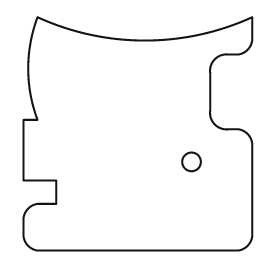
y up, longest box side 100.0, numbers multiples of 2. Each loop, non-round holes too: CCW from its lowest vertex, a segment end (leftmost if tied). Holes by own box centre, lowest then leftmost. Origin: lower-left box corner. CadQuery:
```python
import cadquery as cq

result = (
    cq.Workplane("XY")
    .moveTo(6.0, 0.0)
    .lineTo(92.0, 0.0)
    .threePointArc((96.0, 2.0), (98.0, 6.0))
    .lineTo(98.0, 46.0)
    .threePointArc((96.0, 50.0), (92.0, 52.0))
    .lineTo(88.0, 52.0)
    .threePointArc((82.0, 54.0), (80.0, 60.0))
    .lineTo(80.0, 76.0)
    .threePointArc((82.0, 82.0), (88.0, 84.0))
    .lineTo(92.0, 84.0)
    .threePointArc((96.0, 86.0), (98.0, 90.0))
    .lineTo(98.0, 100.0)
    .threePointArc((52.0, 90.0), (6.0, 100.0))
    .threePointArc((2.0, 78.0), (6.0, 56.0))
    .lineTo(0.0, 56.0)
    .lineTo(0.0, 30.0)
    .lineTo(14.0, 30.0)
    .lineTo(14.0, 20.0)
    .lineTo(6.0, 20.0)
    .threePointArc((2.0, 18.0), (0.0, 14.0))
    .lineTo(0.0, 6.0)
    .threePointArc((2.0, 2.0), (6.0, 0.0))
    .close()
    .moveTo(72.0, 38.0)
    .circle(4.0)
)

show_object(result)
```